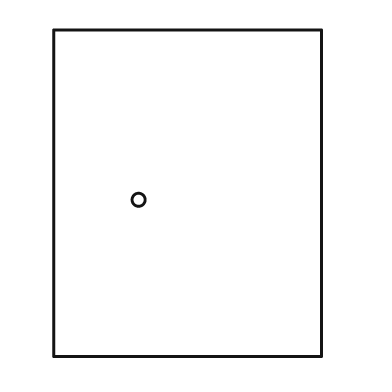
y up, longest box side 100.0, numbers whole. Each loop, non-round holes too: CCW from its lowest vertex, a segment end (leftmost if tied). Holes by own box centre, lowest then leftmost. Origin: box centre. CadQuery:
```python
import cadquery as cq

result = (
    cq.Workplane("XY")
    .moveTo(-41.0, -50.0)
    .lineTo(41.0, -50.0)
    .lineTo(41.0, 50.0)
    .lineTo(-41.0, 50.0)
    .close()
    .moveTo(-15.0, -2.0)
    .circle(2.0)
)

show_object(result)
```